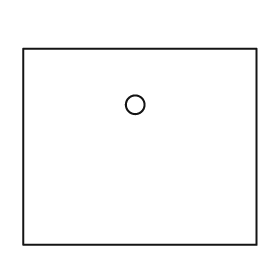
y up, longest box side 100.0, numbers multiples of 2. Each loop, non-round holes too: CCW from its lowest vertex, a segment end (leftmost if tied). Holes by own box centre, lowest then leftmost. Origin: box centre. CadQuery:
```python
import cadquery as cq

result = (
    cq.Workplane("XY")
    .moveTo(-50.0, -42.0)
    .lineTo(50.0, -42.0)
    .lineTo(50.0, 42.0)
    .lineTo(-50.0, 42.0)
    .close()
    .moveTo(-2.0, 18.0)
    .circle(4.0)
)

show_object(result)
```